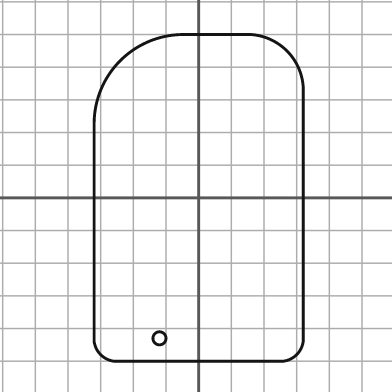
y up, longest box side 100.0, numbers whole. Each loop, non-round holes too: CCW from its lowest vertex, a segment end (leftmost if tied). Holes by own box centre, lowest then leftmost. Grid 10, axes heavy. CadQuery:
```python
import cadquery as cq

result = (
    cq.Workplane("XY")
    .moveTo(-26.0, -50.0)
    .lineTo(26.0, -50.0)
    .threePointArc((30.0, -48.0), (32.0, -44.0))
    .lineTo(32.0, 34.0)
    .threePointArc((27.0, 45.0), (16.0, 50.0))
    .lineTo(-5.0, 50.0)
    .threePointArc((-24.0, 42.0), (-32.0, 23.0))
    .lineTo(-32.0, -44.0)
    .threePointArc((-30.0, -48.0), (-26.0, -50.0))
    .close()
    .moveTo(-12.0, -43.0)
    .circle(2.0)
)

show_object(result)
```